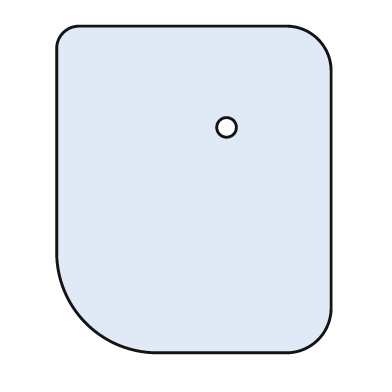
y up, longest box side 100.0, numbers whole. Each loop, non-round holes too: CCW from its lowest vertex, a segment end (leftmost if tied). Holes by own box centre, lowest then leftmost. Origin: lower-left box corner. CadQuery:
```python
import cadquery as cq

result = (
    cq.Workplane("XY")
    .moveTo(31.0, 0.0)
    .lineTo(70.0, 0.0)
    .threePointArc((80.0, 4.0), (84.0, 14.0))
    .lineTo(84.0, 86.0)
    .threePointArc((80.0, 96.0), (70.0, 100.0))
    .lineTo(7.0, 100.0)
    .threePointArc((2.0, 98.0), (0.0, 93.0))
    .lineTo(0.0, 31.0)
    .threePointArc((9.0, 9.0), (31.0, 0.0))
    .close()
    .moveTo(52.0, 69.0)
    .circle(3.0)
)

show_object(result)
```